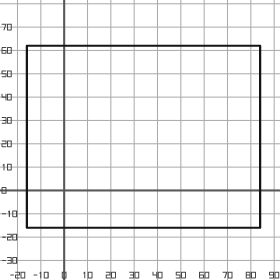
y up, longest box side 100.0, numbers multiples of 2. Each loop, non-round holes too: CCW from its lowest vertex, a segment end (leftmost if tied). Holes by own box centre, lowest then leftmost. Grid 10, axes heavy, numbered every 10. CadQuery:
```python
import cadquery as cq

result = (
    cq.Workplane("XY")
    .moveTo(-16.0, -16.0)
    .lineTo(84.0, -16.0)
    .lineTo(84.0, 62.0)
    .lineTo(-16.0, 62.0)
    .close()
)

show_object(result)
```